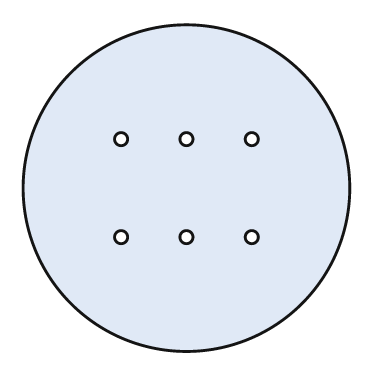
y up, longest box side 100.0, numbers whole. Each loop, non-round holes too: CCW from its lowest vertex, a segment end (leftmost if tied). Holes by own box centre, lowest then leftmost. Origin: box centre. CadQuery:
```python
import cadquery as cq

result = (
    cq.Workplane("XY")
    .moveTo(0.0, 0.0)
    .circle(50.0)
    .moveTo(-20.0, -15.0)
    .circle(2.0)
    .moveTo(0.0, -15.0)
    .circle(2.0)
    .moveTo(20.0, -15.0)
    .circle(2.0)
    .moveTo(-20.0, 15.0)
    .circle(2.0)
    .moveTo(0.0, 15.0)
    .circle(2.0)
    .moveTo(20.0, 15.0)
    .circle(2.0)
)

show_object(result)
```